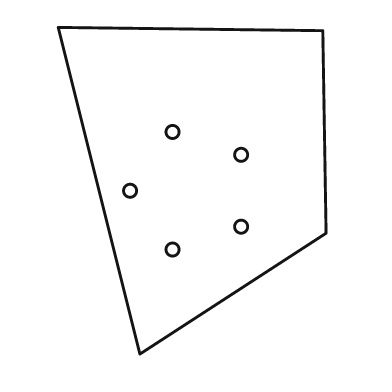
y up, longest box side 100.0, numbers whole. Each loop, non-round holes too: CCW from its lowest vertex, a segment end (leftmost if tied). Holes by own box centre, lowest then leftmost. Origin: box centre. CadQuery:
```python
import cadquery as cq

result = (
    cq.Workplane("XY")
    .moveTo(-16.0, -50.0)
    .lineTo(41.0, -13.0)
    .lineTo(40.0, 49.0)
    .lineTo(-41.0, 50.0)
    .close()
    .moveTo(-6.0, -18.0)
    .circle(2.0)
    .moveTo(15.0, -11.0)
    .circle(2.0)
    .moveTo(-19.0, 0.0)
    .circle(2.0)
    .moveTo(15.0, 11.0)
    .circle(2.0)
    .moveTo(-6.0, 18.0)
    .circle(2.0)
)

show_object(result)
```